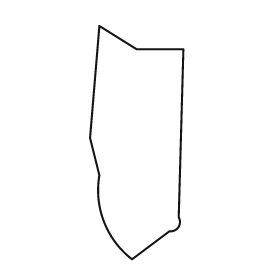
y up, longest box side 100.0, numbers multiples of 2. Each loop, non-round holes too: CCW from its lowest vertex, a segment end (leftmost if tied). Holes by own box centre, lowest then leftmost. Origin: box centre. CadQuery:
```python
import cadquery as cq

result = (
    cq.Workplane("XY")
    .moveTo(-2.0, -50.0)
    .lineTo(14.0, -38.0)
    .threePointArc((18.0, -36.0), (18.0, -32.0))
    .lineTo(20.0, 40.0)
    .lineTo(0.0, 40.0)
    .lineTo(-16.0, 50.0)
    .lineTo(-20.0, 2.0)
    .lineTo(-16.0, -14.0)
    .threePointArc((-14.0, -34.0), (-2.0, -50.0))
    .close()
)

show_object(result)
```